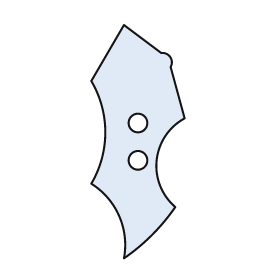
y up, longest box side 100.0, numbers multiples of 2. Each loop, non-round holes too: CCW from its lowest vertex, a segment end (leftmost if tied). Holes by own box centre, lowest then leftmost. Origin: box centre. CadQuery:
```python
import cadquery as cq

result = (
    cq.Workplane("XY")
    .moveTo(-6.0, -50.0)
    .threePointArc((6.0, -40.0), (16.0, -28.0))
    .threePointArc((8.0, -8.0), (20.0, 10.0))
    .lineTo(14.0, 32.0)
    .threePointArc((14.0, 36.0), (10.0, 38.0))
    .lineTo(-6.0, 50.0)
    .lineTo(-20.0, 26.0)
    .threePointArc((-14.0, 4.0), (-20.0, -18.0))
    .threePointArc((-8.0, -32.0), (-6.0, -50.0))
    .close()
    .moveTo(0.0, -8.0)
    .circle(4.0)
    .moveTo(0.0, 8.0)
    .circle(4.0)
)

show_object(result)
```